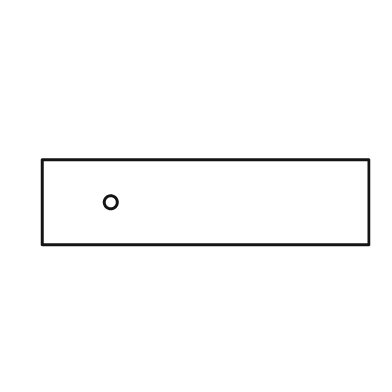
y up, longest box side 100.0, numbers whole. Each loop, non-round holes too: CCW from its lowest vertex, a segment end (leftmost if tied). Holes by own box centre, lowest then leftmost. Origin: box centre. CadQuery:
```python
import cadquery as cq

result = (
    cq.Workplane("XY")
    .moveTo(-50.0, -13.0)
    .lineTo(50.0, -13.0)
    .lineTo(50.0, 13.0)
    .lineTo(-50.0, 13.0)
    .close()
    .moveTo(-29.0, 0.0)
    .circle(2.0)
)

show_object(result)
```